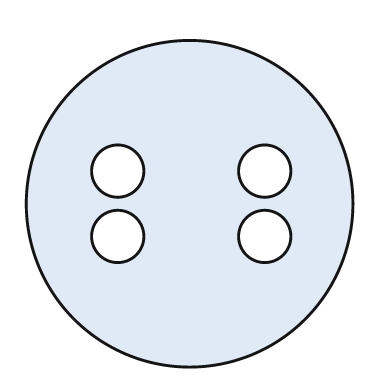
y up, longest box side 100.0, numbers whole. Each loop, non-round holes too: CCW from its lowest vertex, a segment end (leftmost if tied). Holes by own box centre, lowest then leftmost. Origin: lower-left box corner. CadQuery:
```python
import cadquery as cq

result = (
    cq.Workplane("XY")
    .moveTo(50.0, 50.0)
    .circle(50.0)
    .moveTo(28.0, 40.0)
    .circle(8.0)
    .moveTo(73.0, 40.0)
    .circle(8.0)
    .moveTo(28.0, 60.0)
    .circle(8.0)
    .moveTo(73.0, 60.0)
    .circle(8.0)
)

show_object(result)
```